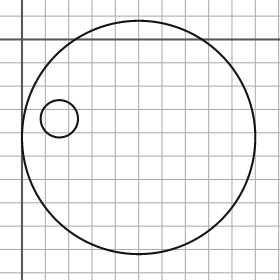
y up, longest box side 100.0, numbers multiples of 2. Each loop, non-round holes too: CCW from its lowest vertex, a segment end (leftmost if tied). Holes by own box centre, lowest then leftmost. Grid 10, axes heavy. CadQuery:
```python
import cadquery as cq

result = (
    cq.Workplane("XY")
    .moveTo(50.0, -42.0)
    .circle(50.0)
    .moveTo(16.0, -34.0)
    .circle(8.0)
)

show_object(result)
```